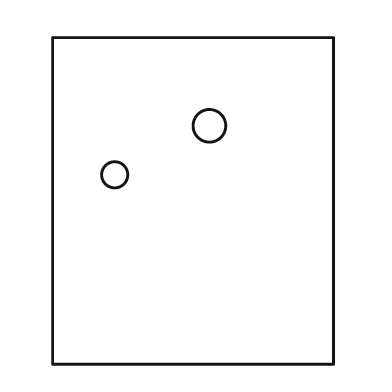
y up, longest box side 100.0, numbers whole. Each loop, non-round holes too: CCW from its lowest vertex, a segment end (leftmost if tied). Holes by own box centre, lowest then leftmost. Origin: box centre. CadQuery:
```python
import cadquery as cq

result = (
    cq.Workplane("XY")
    .moveTo(-43.0, -50.0)
    .lineTo(43.0, -50.0)
    .lineTo(43.0, 50.0)
    .lineTo(-43.0, 50.0)
    .close()
    .moveTo(-24.0, 8.0)
    .circle(4.0)
    .moveTo(5.0, 23.0)
    .circle(5.0)
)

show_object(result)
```